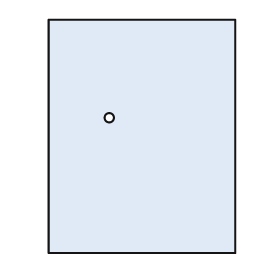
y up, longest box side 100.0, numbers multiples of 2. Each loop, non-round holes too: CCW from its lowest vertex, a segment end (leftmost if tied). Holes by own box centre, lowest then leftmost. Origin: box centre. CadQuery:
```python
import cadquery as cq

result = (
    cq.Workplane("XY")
    .moveTo(-40.0, -50.0)
    .lineTo(40.0, -50.0)
    .lineTo(40.0, 50.0)
    .lineTo(-40.0, 50.0)
    .close()
    .moveTo(-14.0, 8.0)
    .circle(2.0)
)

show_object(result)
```